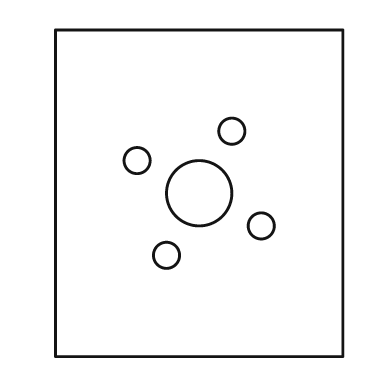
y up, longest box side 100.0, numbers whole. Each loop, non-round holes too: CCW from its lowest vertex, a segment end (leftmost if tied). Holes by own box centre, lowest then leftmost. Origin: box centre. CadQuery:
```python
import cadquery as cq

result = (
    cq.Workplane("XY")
    .moveTo(-44.0, -50.0)
    .lineTo(44.0, -50.0)
    .lineTo(44.0, 50.0)
    .lineTo(-44.0, 50.0)
    .close()
    .moveTo(-10.0, -19.0)
    .circle(4.0)
    .moveTo(19.0, -10.0)
    .circle(4.0)
    .moveTo(0.0, 0.0)
    .circle(10.0)
    .moveTo(-19.0, 10.0)
    .circle(4.0)
    .moveTo(10.0, 19.0)
    .circle(4.0)
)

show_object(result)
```